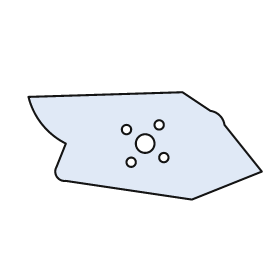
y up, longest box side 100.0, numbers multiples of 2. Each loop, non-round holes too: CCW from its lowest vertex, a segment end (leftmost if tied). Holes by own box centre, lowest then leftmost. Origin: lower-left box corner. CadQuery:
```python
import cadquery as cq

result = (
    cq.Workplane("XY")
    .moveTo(70.0, 0.0)
    .lineTo(100.0, 12.0)
    .lineTo(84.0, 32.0)
    .threePointArc((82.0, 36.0), (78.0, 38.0))
    .lineTo(66.0, 46.0)
    .lineTo(0.0, 44.0)
    .threePointArc((6.0, 32.0), (16.0, 24.0))
    .lineTo(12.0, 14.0)
    .threePointArc((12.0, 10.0), (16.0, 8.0))
    .close()
    .moveTo(44.0, 16.0)
    .circle(2.0)
    .moveTo(58.0, 18.0)
    .circle(2.0)
    .moveTo(50.0, 24.0)
    .circle(4.0)
    .moveTo(42.0, 30.0)
    .circle(2.0)
    .moveTo(56.0, 32.0)
    .circle(2.0)
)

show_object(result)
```